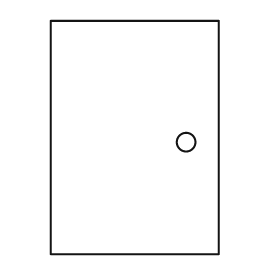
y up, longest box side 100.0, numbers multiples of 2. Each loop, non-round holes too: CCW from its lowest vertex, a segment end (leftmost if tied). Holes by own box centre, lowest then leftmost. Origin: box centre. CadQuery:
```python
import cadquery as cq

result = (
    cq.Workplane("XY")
    .moveTo(-36.0, -50.0)
    .lineTo(36.0, -50.0)
    .lineTo(36.0, 50.0)
    .lineTo(-36.0, 50.0)
    .close()
    .moveTo(22.0, -2.0)
    .circle(4.0)
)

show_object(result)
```